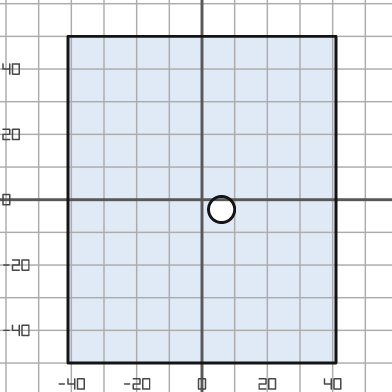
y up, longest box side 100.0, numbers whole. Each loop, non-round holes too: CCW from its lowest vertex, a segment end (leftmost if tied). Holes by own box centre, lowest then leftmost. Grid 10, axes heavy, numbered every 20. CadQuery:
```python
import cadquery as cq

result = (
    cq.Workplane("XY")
    .moveTo(-41.0, -50.0)
    .lineTo(41.0, -50.0)
    .lineTo(41.0, 50.0)
    .lineTo(-41.0, 50.0)
    .close()
    .moveTo(6.0, -3.0)
    .circle(4.0)
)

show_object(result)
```